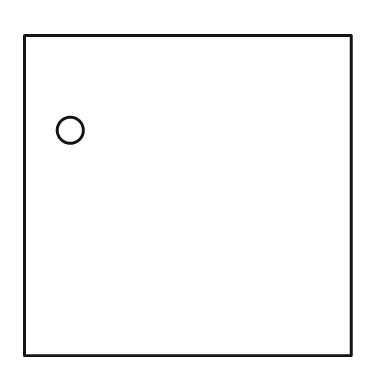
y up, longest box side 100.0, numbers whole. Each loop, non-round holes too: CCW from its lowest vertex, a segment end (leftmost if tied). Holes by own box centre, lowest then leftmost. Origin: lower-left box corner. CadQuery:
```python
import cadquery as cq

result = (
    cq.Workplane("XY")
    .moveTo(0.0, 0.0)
    .lineTo(100.0, 0.0)
    .lineTo(100.0, 98.0)
    .lineTo(0.0, 98.0)
    .close()
    .moveTo(14.0, 69.0)
    .circle(4.0)
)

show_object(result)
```